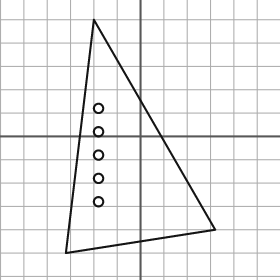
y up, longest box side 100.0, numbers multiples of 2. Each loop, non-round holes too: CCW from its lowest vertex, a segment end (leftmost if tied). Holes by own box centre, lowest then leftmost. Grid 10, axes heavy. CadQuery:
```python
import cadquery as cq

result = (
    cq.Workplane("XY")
    .moveTo(-32.0, -50.0)
    .lineTo(32.0, -40.0)
    .lineTo(-20.0, 50.0)
    .close()
    .moveTo(-18.0, -28.0)
    .circle(2.0)
    .moveTo(-18.0, -18.0)
    .circle(2.0)
    .moveTo(-18.0, -8.0)
    .circle(2.0)
    .moveTo(-18.0, 2.0)
    .circle(2.0)
    .moveTo(-18.0, 12.0)
    .circle(2.0)
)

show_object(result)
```